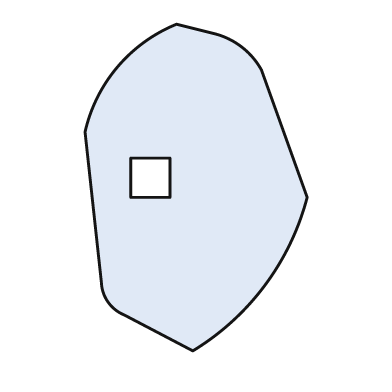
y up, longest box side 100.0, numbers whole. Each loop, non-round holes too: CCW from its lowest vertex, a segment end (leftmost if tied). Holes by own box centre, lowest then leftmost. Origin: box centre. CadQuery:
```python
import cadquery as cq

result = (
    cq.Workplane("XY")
    .moveTo(-1.0, -50.0)
    .threePointArc((21.0, -30.0), (34.0, -3.0))
    .lineTo(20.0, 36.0)
    .threePointArc((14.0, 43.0), (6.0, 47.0))
    .lineTo(-6.0, 50.0)
    .threePointArc((-24.0, 37.0), (-34.0, 17.0))
    .lineTo(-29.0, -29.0)
    .threePointArc((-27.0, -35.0), (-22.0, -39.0))
    .close()
    .moveTo(-20.0, -3.0)
    .lineTo(-8.0, -3.0)
    .lineTo(-8.0, 9.0)
    .lineTo(-20.0, 9.0)
    .close()
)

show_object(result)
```